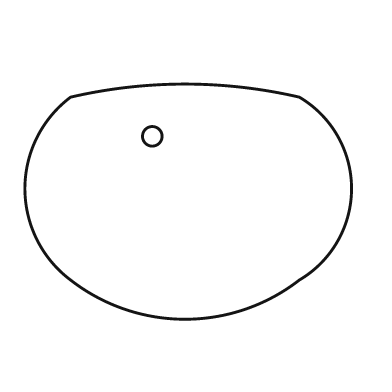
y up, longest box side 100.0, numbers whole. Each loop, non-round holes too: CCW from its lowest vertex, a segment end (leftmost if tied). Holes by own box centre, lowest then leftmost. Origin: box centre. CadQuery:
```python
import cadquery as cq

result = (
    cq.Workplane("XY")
    .moveTo(-36.0, -24.0)
    .threePointArc((-1.0, -36.0), (34.0, -24.0))
    .threePointArc((50.0, 4.0), (34.0, 32.0))
    .threePointArc((-1.0, 36.0), (-36.0, 32.0))
    .threePointArc((-50.0, 4.0), (-36.0, -24.0))
    .close()
    .moveTo(-11.0, 20.0)
    .circle(3.0)
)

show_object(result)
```